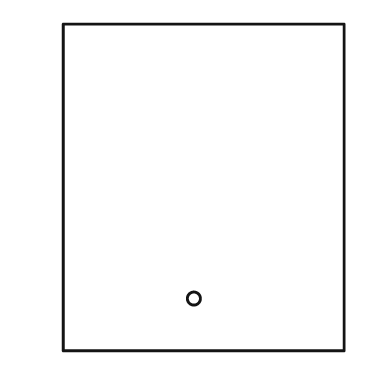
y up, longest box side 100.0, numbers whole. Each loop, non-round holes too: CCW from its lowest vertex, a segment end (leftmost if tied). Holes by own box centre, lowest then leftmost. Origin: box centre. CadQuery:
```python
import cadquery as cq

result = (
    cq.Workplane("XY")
    .moveTo(-43.0, -50.0)
    .lineTo(43.0, -50.0)
    .lineTo(43.0, 50.0)
    .lineTo(-43.0, 50.0)
    .close()
    .moveTo(-3.0, -34.0)
    .circle(2.0)
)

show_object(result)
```